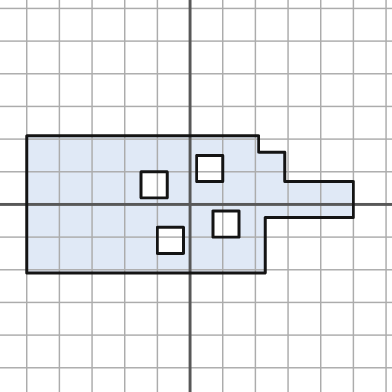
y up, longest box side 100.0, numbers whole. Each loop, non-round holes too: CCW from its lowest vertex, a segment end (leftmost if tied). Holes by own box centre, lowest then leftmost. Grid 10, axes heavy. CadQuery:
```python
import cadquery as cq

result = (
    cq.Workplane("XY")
    .moveTo(-50.0, -21.0)
    .lineTo(23.0, -21.0)
    .lineTo(23.0, -4.0)
    .lineTo(50.0, -4.0)
    .lineTo(50.0, 7.0)
    .lineTo(29.0, 7.0)
    .lineTo(29.0, 16.0)
    .lineTo(21.0, 16.0)
    .lineTo(21.0, 21.0)
    .lineTo(-50.0, 21.0)
    .close()
    .moveTo(-10.0, -15.0)
    .lineTo(-2.0, -15.0)
    .lineTo(-2.0, -7.0)
    .lineTo(-10.0, -7.0)
    .close()
    .moveTo(7.0, -10.0)
    .lineTo(15.0, -10.0)
    .lineTo(15.0, -2.0)
    .lineTo(7.0, -2.0)
    .close()
    .moveTo(-15.0, 2.0)
    .lineTo(-7.0, 2.0)
    .lineTo(-7.0, 10.0)
    .lineTo(-15.0, 10.0)
    .close()
    .moveTo(2.0, 7.0)
    .lineTo(10.0, 7.0)
    .lineTo(10.0, 15.0)
    .lineTo(2.0, 15.0)
    .close()
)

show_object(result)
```